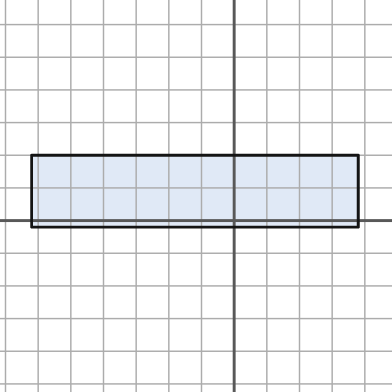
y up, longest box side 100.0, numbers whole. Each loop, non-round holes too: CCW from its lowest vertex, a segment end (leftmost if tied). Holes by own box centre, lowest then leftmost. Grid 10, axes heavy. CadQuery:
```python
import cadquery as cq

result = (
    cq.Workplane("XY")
    .moveTo(-62.0, -2.0)
    .lineTo(38.0, -2.0)
    .lineTo(38.0, 20.0)
    .lineTo(-62.0, 20.0)
    .close()
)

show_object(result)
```